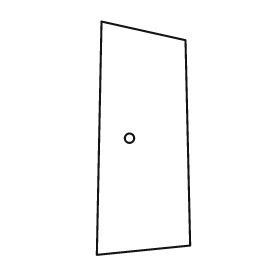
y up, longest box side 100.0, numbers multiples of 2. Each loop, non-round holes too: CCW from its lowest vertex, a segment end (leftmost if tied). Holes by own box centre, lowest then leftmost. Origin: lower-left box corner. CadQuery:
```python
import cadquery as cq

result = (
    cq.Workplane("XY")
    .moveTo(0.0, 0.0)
    .lineTo(40.0, 4.0)
    .lineTo(38.0, 92.0)
    .lineTo(2.0, 100.0)
    .close()
    .moveTo(14.0, 50.0)
    .circle(2.0)
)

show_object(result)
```